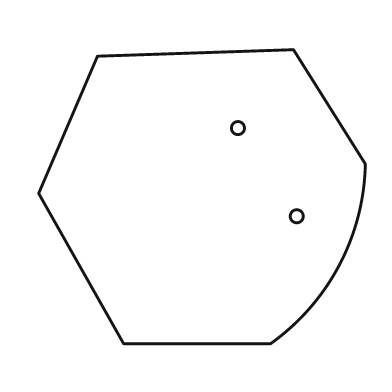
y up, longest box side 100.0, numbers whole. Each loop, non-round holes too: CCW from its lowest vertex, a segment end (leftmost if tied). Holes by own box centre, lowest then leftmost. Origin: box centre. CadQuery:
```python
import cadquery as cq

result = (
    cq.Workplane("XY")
    .moveTo(-24.0, -45.0)
    .lineTo(21.0, -45.0)
    .threePointArc((42.0, -21.0), (50.0, 10.0))
    .lineTo(28.0, 45.0)
    .lineTo(-32.0, 43.0)
    .lineTo(-50.0, 1.0)
    .close()
    .moveTo(29.0, -6.0)
    .circle(2.0)
    .moveTo(11.0, 21.0)
    .circle(2.0)
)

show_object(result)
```